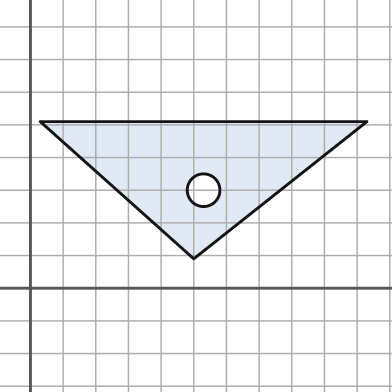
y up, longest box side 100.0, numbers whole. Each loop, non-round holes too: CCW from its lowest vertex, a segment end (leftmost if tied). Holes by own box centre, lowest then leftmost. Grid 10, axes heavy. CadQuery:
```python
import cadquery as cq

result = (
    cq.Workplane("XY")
    .moveTo(50.0, 9.0)
    .lineTo(103.0, 51.0)
    .lineTo(3.0, 51.0)
    .close()
    .moveTo(53.0, 30.0)
    .circle(5.0)
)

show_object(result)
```